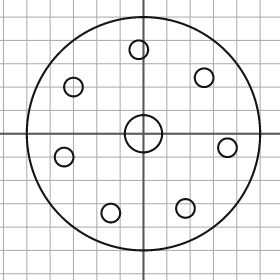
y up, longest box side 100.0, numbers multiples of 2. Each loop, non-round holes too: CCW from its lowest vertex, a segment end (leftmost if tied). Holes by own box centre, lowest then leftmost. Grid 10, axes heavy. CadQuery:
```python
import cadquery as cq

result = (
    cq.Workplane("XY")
    .moveTo(0.0, 0.0)
    .circle(50.0)
    .moveTo(-14.0, -34.0)
    .circle(4.0)
    .moveTo(18.0, -32.0)
    .circle(4.0)
    .moveTo(-34.0, -10.0)
    .circle(4.0)
    .moveTo(36.0, -6.0)
    .circle(4.0)
    .moveTo(0.0, 0.0)
    .circle(8.0)
    .moveTo(-30.0, 20.0)
    .circle(4.0)
    .moveTo(26.0, 24.0)
    .circle(4.0)
    .moveTo(-2.0, 36.0)
    .circle(4.0)
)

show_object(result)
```